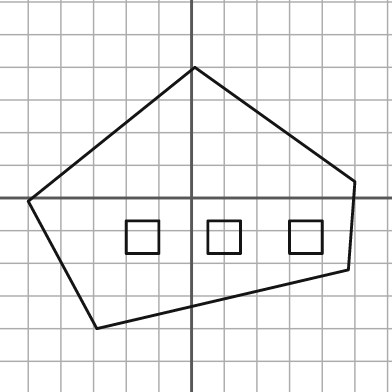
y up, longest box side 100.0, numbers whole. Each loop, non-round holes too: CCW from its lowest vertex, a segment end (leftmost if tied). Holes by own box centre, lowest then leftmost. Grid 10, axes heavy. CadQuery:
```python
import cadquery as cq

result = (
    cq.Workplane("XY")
    .moveTo(-29.0, -40.0)
    .lineTo(48.0, -22.0)
    .lineTo(50.0, 5.0)
    .lineTo(1.0, 40.0)
    .lineTo(-50.0, -1.0)
    .close()
    .moveTo(-20.0, -17.0)
    .lineTo(-10.0, -17.0)
    .lineTo(-10.0, -7.0)
    .lineTo(-20.0, -7.0)
    .close()
    .moveTo(5.0, -17.0)
    .lineTo(15.0, -17.0)
    .lineTo(15.0, -7.0)
    .lineTo(5.0, -7.0)
    .close()
    .moveTo(30.0, -17.0)
    .lineTo(40.0, -17.0)
    .lineTo(40.0, -7.0)
    .lineTo(30.0, -7.0)
    .close()
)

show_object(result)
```